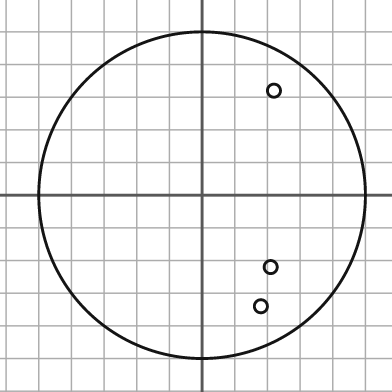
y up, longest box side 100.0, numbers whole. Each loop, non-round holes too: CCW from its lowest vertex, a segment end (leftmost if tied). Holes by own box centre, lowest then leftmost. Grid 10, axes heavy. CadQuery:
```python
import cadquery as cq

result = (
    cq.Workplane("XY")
    .moveTo(0.0, 0.0)
    .circle(50.0)
    .moveTo(18.0, -34.0)
    .circle(2.0)
    .moveTo(21.0, -22.0)
    .circle(2.0)
    .moveTo(22.0, 32.0)
    .circle(2.0)
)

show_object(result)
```